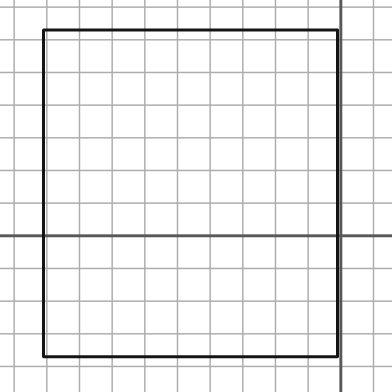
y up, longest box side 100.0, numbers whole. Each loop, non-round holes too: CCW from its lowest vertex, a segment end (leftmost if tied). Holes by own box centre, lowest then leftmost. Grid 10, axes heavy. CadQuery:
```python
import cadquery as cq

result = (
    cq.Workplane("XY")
    .moveTo(-91.0, -37.0)
    .lineTo(-1.0, -37.0)
    .lineTo(-1.0, 63.0)
    .lineTo(-91.0, 63.0)
    .close()
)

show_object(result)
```